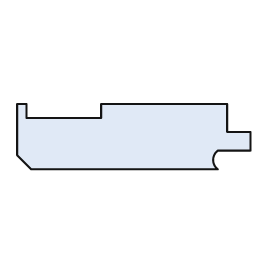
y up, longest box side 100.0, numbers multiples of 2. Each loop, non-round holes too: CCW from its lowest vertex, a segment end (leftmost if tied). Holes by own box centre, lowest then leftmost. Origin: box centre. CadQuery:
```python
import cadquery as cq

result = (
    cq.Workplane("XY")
    .moveTo(-44.0, -14.0)
    .lineTo(36.0, -14.0)
    .threePointArc((34.0, -10.0), (36.0, -6.0))
    .lineTo(50.0, -6.0)
    .lineTo(50.0, 2.0)
    .lineTo(40.0, 2.0)
    .lineTo(40.0, 14.0)
    .lineTo(-14.0, 14.0)
    .lineTo(-14.0, 8.0)
    .lineTo(-46.0, 8.0)
    .lineTo(-46.0, 14.0)
    .lineTo(-50.0, 14.0)
    .lineTo(-50.0, -8.0)
    .close()
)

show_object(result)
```